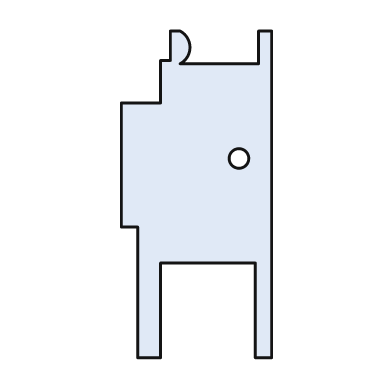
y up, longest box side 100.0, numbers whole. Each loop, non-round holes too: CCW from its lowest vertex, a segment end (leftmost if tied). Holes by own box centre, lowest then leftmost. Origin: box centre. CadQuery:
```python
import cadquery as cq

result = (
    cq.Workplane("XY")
    .moveTo(-18.0, -50.0)
    .lineTo(-11.0, -50.0)
    .lineTo(-11.0, -21.0)
    .lineTo(18.0, -21.0)
    .lineTo(18.0, -50.0)
    .lineTo(23.0, -50.0)
    .lineTo(23.0, 50.0)
    .lineTo(19.0, 50.0)
    .lineTo(19.0, 40.0)
    .lineTo(-5.0, 40.0)
    .threePointArc((-2.0, 45.0), (-5.0, 50.0))
    .lineTo(-8.0, 50.0)
    .lineTo(-8.0, 41.0)
    .lineTo(-11.0, 41.0)
    .lineTo(-11.0, 28.0)
    .lineTo(-23.0, 28.0)
    .lineTo(-23.0, -10.0)
    .lineTo(-18.0, -10.0)
    .close()
    .moveTo(13.0, 11.0)
    .circle(3.0)
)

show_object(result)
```